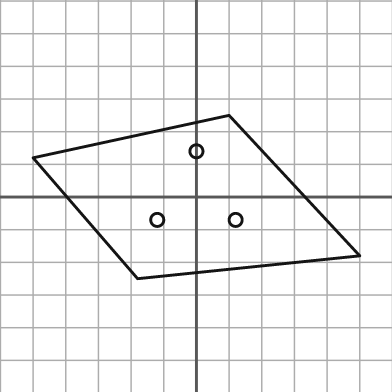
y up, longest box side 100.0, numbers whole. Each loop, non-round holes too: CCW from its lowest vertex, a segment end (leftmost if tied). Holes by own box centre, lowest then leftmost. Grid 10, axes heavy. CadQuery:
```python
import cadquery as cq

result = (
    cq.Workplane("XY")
    .moveTo(-18.0, -25.0)
    .lineTo(50.0, -18.0)
    .lineTo(10.0, 25.0)
    .lineTo(-50.0, 12.0)
    .close()
    .moveTo(-12.0, -7.0)
    .circle(2.0)
    .moveTo(12.0, -7.0)
    .circle(2.0)
    .moveTo(0.0, 14.0)
    .circle(2.0)
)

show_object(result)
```